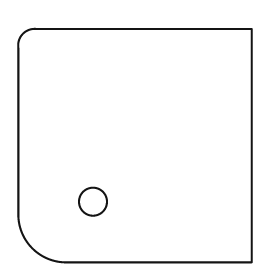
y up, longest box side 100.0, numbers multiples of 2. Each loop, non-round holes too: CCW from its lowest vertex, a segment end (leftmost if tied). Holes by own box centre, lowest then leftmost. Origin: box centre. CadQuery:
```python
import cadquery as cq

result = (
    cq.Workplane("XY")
    .moveTo(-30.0, -50.0)
    .lineTo(50.0, -50.0)
    .lineTo(50.0, 50.0)
    .lineTo(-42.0, 50.0)
    .threePointArc((-48.0, 48.0), (-50.0, 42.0))
    .lineTo(-50.0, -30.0)
    .threePointArc((-44.0, -44.0), (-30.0, -50.0))
    .close()
    .moveTo(-18.0, -24.0)
    .circle(6.0)
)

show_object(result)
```